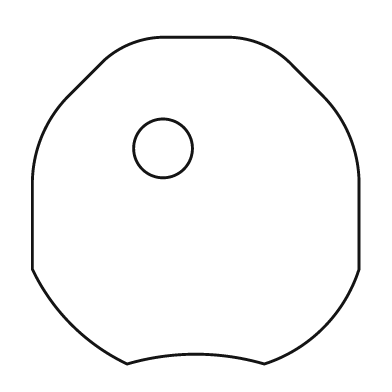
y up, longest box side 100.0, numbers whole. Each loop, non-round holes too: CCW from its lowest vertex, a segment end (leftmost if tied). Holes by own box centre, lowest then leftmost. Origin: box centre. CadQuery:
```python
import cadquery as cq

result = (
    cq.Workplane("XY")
    .moveTo(-21.0, -50.0)
    .threePointArc((0.0, -47.0), (21.0, -50.0))
    .threePointArc((39.0, -39.0), (50.0, -21.0))
    .lineTo(50.0, 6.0)
    .threePointArc((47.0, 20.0), (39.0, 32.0))
    .lineTo(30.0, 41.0)
    .threePointArc((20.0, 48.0), (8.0, 50.0))
    .lineTo(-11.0, 50.0)
    .threePointArc((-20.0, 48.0), (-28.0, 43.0))
    .lineTo(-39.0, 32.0)
    .threePointArc((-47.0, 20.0), (-50.0, 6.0))
    .lineTo(-50.0, -21.0)
    .threePointArc((-38.0, -38.0), (-21.0, -50.0))
    .close()
    .moveTo(-10.0, 16.0)
    .circle(9.0)
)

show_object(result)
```